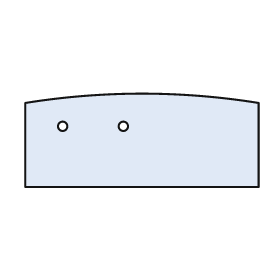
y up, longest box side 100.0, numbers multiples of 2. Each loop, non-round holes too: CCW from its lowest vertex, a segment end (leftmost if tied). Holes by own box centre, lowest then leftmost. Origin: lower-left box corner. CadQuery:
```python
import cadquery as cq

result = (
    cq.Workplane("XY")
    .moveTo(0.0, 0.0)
    .lineTo(100.0, 0.0)
    .lineTo(100.0, 36.0)
    .threePointArc((50.0, 40.0), (0.0, 36.0))
    .close()
    .moveTo(16.0, 26.0)
    .circle(2.0)
    .moveTo(42.0, 26.0)
    .circle(2.0)
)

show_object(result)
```